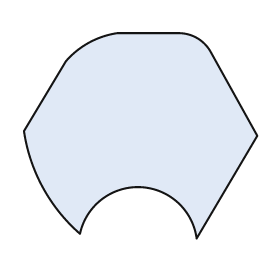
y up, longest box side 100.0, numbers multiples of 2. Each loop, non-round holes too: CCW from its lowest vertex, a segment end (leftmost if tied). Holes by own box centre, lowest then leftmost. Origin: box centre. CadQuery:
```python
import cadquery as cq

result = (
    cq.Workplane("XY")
    .moveTo(24.0, -44.0)
    .lineTo(50.0, 0.0)
    .lineTo(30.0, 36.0)
    .threePointArc((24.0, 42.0), (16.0, 44.0))
    .lineTo(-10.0, 44.0)
    .threePointArc((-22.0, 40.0), (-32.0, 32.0))
    .lineTo(-50.0, 2.0)
    .threePointArc((-42.0, -22.0), (-26.0, -42.0))
    .threePointArc((0.0, -22.0), (24.0, -44.0))
    .close()
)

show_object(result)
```